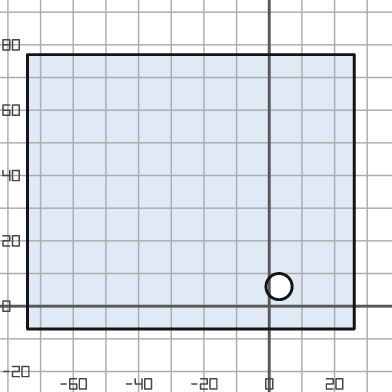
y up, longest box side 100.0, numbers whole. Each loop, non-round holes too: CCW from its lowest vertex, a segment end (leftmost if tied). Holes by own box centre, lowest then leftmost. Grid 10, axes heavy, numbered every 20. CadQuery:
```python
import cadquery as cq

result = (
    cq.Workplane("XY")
    .moveTo(-74.0, -7.0)
    .lineTo(26.0, -7.0)
    .lineTo(26.0, 77.0)
    .lineTo(-74.0, 77.0)
    .close()
    .moveTo(3.0, 6.0)
    .circle(4.0)
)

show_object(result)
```